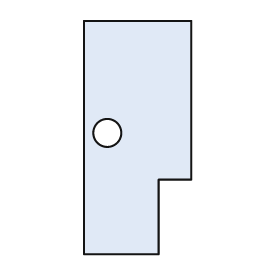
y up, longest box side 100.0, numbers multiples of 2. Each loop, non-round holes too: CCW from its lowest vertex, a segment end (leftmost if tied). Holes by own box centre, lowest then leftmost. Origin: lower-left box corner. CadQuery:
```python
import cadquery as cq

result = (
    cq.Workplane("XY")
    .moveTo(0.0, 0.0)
    .lineTo(32.0, 0.0)
    .lineTo(32.0, 32.0)
    .lineTo(46.0, 32.0)
    .lineTo(46.0, 100.0)
    .lineTo(0.0, 100.0)
    .close()
    .moveTo(10.0, 52.0)
    .circle(6.0)
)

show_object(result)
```